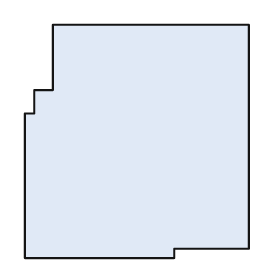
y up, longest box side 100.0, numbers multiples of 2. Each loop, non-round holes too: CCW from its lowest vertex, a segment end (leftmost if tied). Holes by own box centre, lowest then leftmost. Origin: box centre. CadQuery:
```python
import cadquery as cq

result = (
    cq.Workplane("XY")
    .moveTo(-48.0, -50.0)
    .lineTo(16.0, -50.0)
    .lineTo(16.0, -46.0)
    .lineTo(48.0, -46.0)
    .lineTo(48.0, 50.0)
    .lineTo(-36.0, 50.0)
    .lineTo(-36.0, 22.0)
    .lineTo(-44.0, 22.0)
    .lineTo(-44.0, 12.0)
    .lineTo(-48.0, 12.0)
    .close()
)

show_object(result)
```